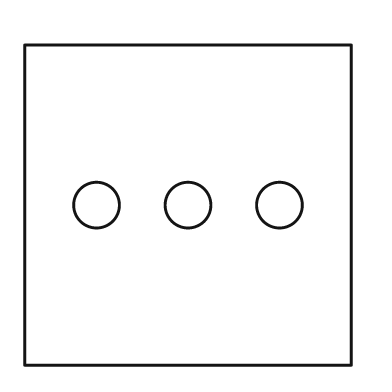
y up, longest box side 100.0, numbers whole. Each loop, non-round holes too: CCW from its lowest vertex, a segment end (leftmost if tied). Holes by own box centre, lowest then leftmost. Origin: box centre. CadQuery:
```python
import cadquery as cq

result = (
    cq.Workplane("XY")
    .moveTo(-50.0, -49.0)
    .lineTo(50.0, -49.0)
    .lineTo(50.0, 49.0)
    .lineTo(-50.0, 49.0)
    .close()
    .moveTo(-28.0, 0.0)
    .circle(7.0)
    .moveTo(0.0, 0.0)
    .circle(7.0)
    .moveTo(28.0, 0.0)
    .circle(7.0)
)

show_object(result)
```